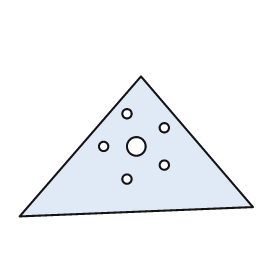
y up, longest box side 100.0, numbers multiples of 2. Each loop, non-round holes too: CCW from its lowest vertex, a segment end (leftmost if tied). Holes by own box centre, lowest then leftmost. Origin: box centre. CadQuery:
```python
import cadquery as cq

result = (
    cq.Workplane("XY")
    .moveTo(-50.0, -30.0)
    .lineTo(50.0, -26.0)
    .lineTo(2.0, 30.0)
    .close()
    .moveTo(-4.0, -14.0)
    .circle(2.0)
    .moveTo(12.0, -8.0)
    .circle(2.0)
    .moveTo(-14.0, 0.0)
    .circle(2.0)
    .moveTo(0.0, 0.0)
    .circle(4.0)
    .moveTo(12.0, 8.0)
    .circle(2.0)
    .moveTo(-4.0, 14.0)
    .circle(2.0)
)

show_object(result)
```